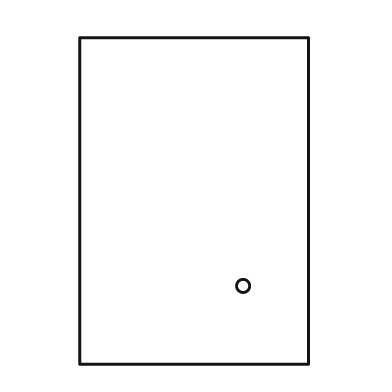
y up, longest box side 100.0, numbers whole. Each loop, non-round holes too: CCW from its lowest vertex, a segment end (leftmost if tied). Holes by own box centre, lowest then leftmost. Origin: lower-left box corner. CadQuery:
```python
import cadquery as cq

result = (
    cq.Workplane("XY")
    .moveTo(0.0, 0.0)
    .lineTo(70.0, 0.0)
    .lineTo(70.0, 100.0)
    .lineTo(0.0, 100.0)
    .close()
    .moveTo(50.0, 24.0)
    .circle(2.0)
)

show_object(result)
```